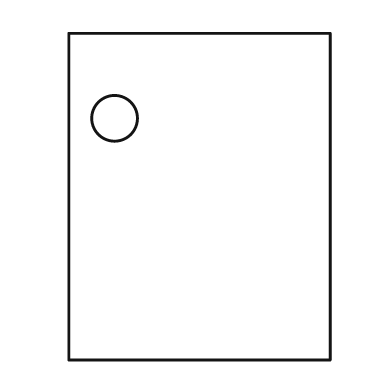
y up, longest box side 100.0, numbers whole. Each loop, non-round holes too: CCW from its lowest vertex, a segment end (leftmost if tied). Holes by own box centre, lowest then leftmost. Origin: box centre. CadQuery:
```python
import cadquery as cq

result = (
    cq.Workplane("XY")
    .moveTo(-40.0, -50.0)
    .lineTo(40.0, -50.0)
    .lineTo(40.0, 50.0)
    .lineTo(-40.0, 50.0)
    .close()
    .moveTo(-26.0, 24.0)
    .circle(7.0)
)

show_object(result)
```